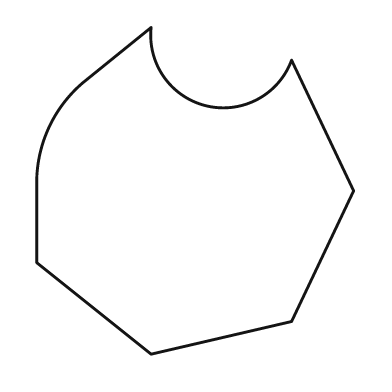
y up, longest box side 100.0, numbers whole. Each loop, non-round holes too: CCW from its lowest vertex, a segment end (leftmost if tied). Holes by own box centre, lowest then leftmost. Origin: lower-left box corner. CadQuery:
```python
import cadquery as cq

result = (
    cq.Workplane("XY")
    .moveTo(35.0, 0.0)
    .lineTo(78.0, 10.0)
    .lineTo(97.0, 50.0)
    .lineTo(78.0, 90.0)
    .threePointArc((52.0, 76.0), (35.0, 100.0))
    .lineTo(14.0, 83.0)
    .threePointArc((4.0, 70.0), (0.0, 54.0))
    .lineTo(0.0, 28.0)
    .close()
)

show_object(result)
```